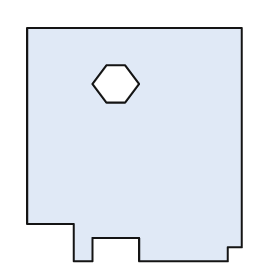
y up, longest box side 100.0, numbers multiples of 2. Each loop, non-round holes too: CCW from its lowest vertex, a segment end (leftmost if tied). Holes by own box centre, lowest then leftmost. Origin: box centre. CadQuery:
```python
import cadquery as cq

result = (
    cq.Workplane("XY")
    .moveTo(-26.0, -50.0)
    .lineTo(-18.0, -50.0)
    .lineTo(-18.0, -40.0)
    .lineTo(2.0, -40.0)
    .lineTo(2.0, -50.0)
    .lineTo(40.0, -50.0)
    .lineTo(40.0, -44.0)
    .lineTo(46.0, -44.0)
    .lineTo(46.0, 50.0)
    .lineTo(-46.0, 50.0)
    .lineTo(-46.0, -34.0)
    .lineTo(-26.0, -34.0)
    .close()
    .moveTo(-12.0, 18.0)
    .lineTo(-4.0, 18.0)
    .lineTo(2.0, 26.0)
    .lineTo(-4.0, 34.0)
    .lineTo(-12.0, 34.0)
    .lineTo(-18.0, 26.0)
    .close()
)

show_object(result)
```